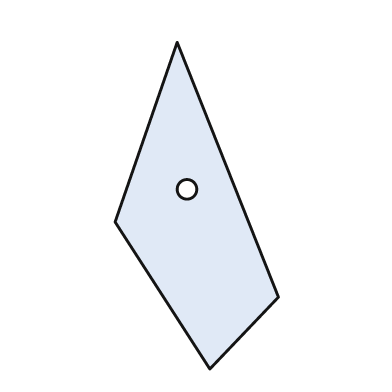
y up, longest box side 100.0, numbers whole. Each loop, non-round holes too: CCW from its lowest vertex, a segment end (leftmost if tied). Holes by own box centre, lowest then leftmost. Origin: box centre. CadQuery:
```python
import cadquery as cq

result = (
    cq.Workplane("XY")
    .moveTo(4.0, -50.0)
    .lineTo(25.0, -28.0)
    .lineTo(-6.0, 50.0)
    .lineTo(-25.0, -5.0)
    .close()
    .moveTo(-3.0, 5.0)
    .circle(3.0)
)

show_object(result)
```